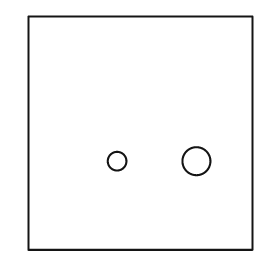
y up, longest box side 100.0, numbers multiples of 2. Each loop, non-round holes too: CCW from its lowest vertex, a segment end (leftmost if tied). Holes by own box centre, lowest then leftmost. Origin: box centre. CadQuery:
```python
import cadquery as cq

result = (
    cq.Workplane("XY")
    .moveTo(-48.0, -50.0)
    .lineTo(48.0, -50.0)
    .lineTo(48.0, 50.0)
    .lineTo(-48.0, 50.0)
    .close()
    .moveTo(-10.0, -12.0)
    .circle(4.0)
    .moveTo(24.0, -12.0)
    .circle(6.0)
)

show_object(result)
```